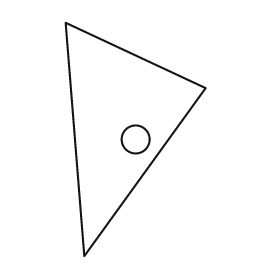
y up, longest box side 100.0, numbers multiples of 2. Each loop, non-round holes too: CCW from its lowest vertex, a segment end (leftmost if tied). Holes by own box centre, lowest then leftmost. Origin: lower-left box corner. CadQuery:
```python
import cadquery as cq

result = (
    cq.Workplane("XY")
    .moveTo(8.0, 0.0)
    .lineTo(60.0, 72.0)
    .lineTo(0.0, 100.0)
    .close()
    .moveTo(30.0, 50.0)
    .circle(6.0)
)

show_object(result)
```